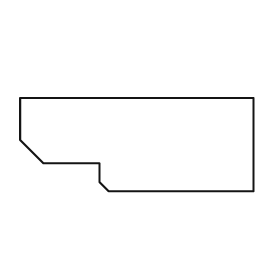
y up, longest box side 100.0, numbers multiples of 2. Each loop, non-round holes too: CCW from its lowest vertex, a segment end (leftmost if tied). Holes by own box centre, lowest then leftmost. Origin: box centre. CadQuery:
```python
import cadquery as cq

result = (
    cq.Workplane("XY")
    .moveTo(-12.0, -20.0)
    .lineTo(50.0, -20.0)
    .lineTo(50.0, 20.0)
    .lineTo(-50.0, 20.0)
    .lineTo(-50.0, 2.0)
    .lineTo(-40.0, -8.0)
    .lineTo(-16.0, -8.0)
    .lineTo(-16.0, -16.0)
    .close()
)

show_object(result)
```